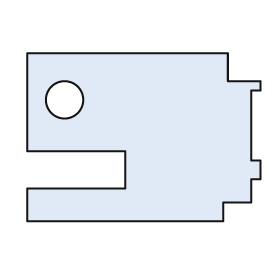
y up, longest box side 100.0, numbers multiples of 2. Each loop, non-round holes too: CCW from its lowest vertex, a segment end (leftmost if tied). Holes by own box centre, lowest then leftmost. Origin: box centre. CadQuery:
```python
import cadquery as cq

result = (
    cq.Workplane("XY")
    .moveTo(-50.0, -36.0)
    .lineTo(34.0, -36.0)
    .lineTo(34.0, -28.0)
    .lineTo(46.0, -28.0)
    .lineTo(46.0, -18.0)
    .lineTo(50.0, -18.0)
    .lineTo(50.0, -10.0)
    .lineTo(46.0, -10.0)
    .lineTo(46.0, 20.0)
    .lineTo(50.0, 20.0)
    .lineTo(50.0, 24.0)
    .lineTo(36.0, 24.0)
    .lineTo(36.0, 36.0)
    .lineTo(-50.0, 36.0)
    .lineTo(-50.0, -6.0)
    .lineTo(-8.0, -6.0)
    .lineTo(-8.0, -22.0)
    .lineTo(-50.0, -22.0)
    .close()
    .moveTo(-34.0, 16.0)
    .circle(8.0)
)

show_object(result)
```